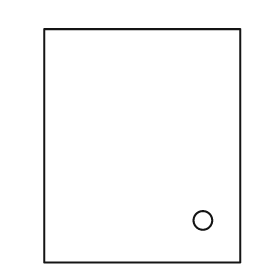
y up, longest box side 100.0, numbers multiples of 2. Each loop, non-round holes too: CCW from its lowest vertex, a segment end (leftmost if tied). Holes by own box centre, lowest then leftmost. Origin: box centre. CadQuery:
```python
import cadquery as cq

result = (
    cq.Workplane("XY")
    .moveTo(-42.0, -50.0)
    .lineTo(42.0, -50.0)
    .lineTo(42.0, 50.0)
    .lineTo(-42.0, 50.0)
    .close()
    .moveTo(26.0, -32.0)
    .circle(4.0)
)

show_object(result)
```